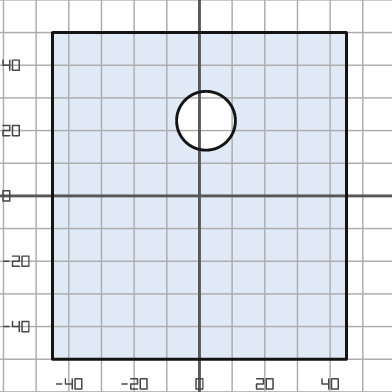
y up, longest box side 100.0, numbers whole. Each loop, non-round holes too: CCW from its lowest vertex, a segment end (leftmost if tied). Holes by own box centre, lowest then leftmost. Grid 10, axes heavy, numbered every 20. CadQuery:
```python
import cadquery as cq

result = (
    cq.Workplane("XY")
    .moveTo(-45.0, -50.0)
    .lineTo(45.0, -50.0)
    .lineTo(45.0, 50.0)
    .lineTo(-45.0, 50.0)
    .close()
    .moveTo(2.0, 23.0)
    .circle(9.0)
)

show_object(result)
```